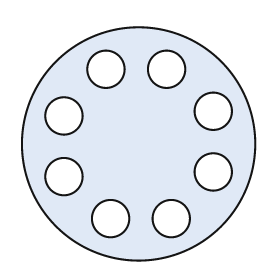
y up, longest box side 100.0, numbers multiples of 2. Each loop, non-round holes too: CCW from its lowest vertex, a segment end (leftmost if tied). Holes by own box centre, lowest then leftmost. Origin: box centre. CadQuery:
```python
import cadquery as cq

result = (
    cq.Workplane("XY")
    .moveTo(0.0, 0.0)
    .circle(50.0)
    .moveTo(-12.0, -32.0)
    .circle(8.0)
    .moveTo(14.0, -32.0)
    .circle(8.0)
    .moveTo(-32.0, -14.0)
    .circle(8.0)
    .moveTo(32.0, -12.0)
    .circle(8.0)
    .moveTo(-32.0, 12.0)
    .circle(8.0)
    .moveTo(32.0, 14.0)
    .circle(8.0)
    .moveTo(-14.0, 32.0)
    .circle(8.0)
    .moveTo(12.0, 32.0)
    .circle(8.0)
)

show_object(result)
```